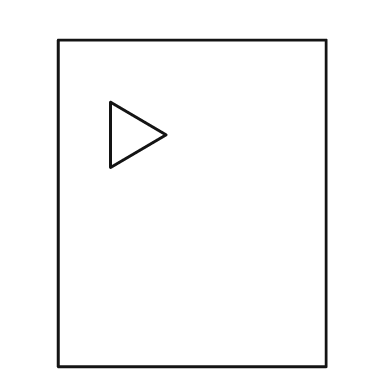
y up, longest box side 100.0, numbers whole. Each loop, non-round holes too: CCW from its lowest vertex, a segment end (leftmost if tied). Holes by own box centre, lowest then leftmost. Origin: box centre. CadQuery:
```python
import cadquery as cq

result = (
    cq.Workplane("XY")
    .moveTo(-41.0, -50.0)
    .lineTo(41.0, -50.0)
    .lineTo(41.0, 50.0)
    .lineTo(-41.0, 50.0)
    .close()
    .moveTo(-25.0, 11.0)
    .lineTo(-8.0, 21.0)
    .lineTo(-25.0, 31.0)
    .close()
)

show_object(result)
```